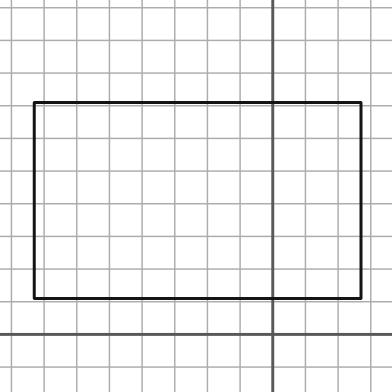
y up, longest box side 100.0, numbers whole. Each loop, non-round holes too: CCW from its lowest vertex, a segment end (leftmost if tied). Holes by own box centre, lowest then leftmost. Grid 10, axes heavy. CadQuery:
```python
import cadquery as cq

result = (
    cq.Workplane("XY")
    .moveTo(-73.0, 11.0)
    .lineTo(27.0, 11.0)
    .lineTo(27.0, 71.0)
    .lineTo(-73.0, 71.0)
    .close()
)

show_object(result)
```